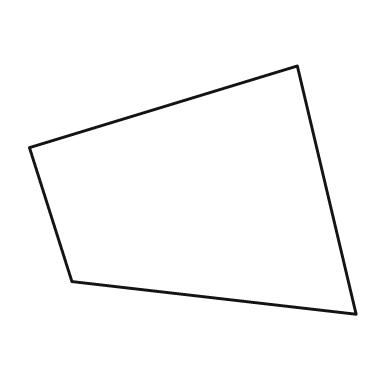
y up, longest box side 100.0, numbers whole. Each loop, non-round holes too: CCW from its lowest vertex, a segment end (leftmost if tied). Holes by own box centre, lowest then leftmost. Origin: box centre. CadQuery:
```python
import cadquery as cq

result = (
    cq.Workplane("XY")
    .moveTo(50.0, -38.0)
    .lineTo(32.0, 38.0)
    .lineTo(-50.0, 13.0)
    .lineTo(-37.0, -28.0)
    .close()
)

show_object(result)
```